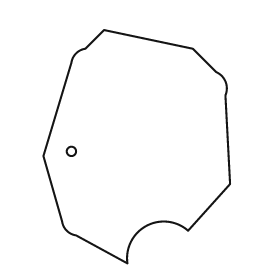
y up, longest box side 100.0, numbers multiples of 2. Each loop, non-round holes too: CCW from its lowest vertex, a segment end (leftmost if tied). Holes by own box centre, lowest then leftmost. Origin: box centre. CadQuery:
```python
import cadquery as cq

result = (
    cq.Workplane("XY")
    .moveTo(-4.0, -50.0)
    .threePointArc((4.0, -34.0), (22.0, -36.0))
    .lineTo(40.0, -16.0)
    .lineTo(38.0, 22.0)
    .threePointArc((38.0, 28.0), (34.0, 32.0))
    .lineTo(24.0, 42.0)
    .lineTo(-14.0, 50.0)
    .lineTo(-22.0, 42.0)
    .threePointArc((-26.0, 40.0), (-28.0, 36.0))
    .lineTo(-40.0, -4.0)
    .lineTo(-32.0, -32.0)
    .threePointArc((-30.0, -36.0), (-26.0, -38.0))
    .close()
    .moveTo(-28.0, -2.0)
    .circle(2.0)
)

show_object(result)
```